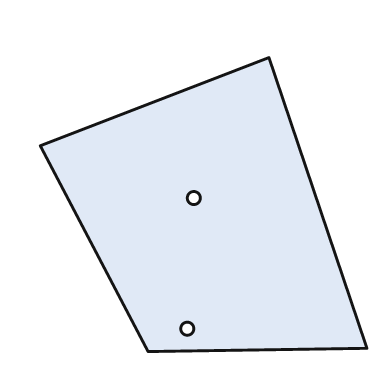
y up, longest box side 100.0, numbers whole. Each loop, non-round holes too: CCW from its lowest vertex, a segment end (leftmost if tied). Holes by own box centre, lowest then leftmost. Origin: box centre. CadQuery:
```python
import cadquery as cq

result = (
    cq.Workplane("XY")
    .moveTo(-17.0, -45.0)
    .lineTo(50.0, -44.0)
    .lineTo(20.0, 45.0)
    .lineTo(-50.0, 18.0)
    .close()
    .moveTo(-5.0, -38.0)
    .circle(2.0)
    .moveTo(-3.0, 2.0)
    .circle(2.0)
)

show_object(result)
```